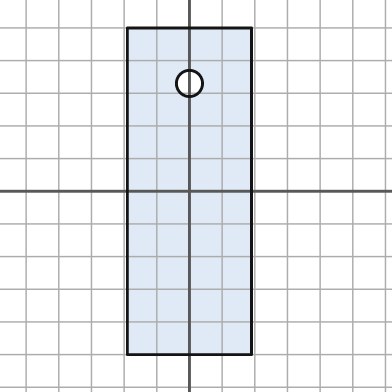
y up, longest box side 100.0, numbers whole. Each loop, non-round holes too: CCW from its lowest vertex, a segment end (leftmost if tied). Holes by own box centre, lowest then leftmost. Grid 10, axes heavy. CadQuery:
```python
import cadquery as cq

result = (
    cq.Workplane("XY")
    .moveTo(-19.0, -50.0)
    .lineTo(19.0, -50.0)
    .lineTo(19.0, 50.0)
    .lineTo(-19.0, 50.0)
    .close()
    .moveTo(0.0, 33.0)
    .circle(4.0)
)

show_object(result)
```